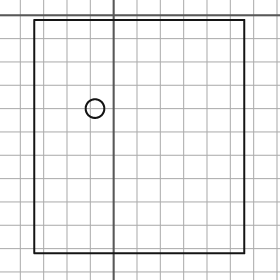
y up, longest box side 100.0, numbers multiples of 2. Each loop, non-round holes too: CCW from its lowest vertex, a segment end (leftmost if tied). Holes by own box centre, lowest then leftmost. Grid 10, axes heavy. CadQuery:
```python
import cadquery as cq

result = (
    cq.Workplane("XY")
    .moveTo(-34.0, -102.0)
    .lineTo(56.0, -102.0)
    .lineTo(56.0, -2.0)
    .lineTo(-34.0, -2.0)
    .close()
    .moveTo(-8.0, -40.0)
    .circle(4.0)
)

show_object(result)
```